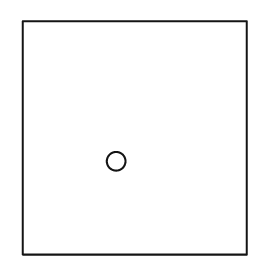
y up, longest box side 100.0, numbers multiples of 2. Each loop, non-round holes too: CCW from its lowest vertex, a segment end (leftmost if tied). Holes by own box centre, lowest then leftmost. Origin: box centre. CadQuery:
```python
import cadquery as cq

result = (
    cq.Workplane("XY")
    .moveTo(-48.0, -50.0)
    .lineTo(48.0, -50.0)
    .lineTo(48.0, 50.0)
    .lineTo(-48.0, 50.0)
    .close()
    .moveTo(-8.0, -10.0)
    .circle(4.0)
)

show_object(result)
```